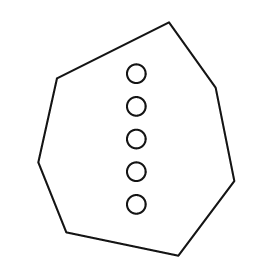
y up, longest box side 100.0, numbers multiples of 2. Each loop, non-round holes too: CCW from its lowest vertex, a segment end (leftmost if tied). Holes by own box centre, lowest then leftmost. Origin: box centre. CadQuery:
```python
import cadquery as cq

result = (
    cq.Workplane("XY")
    .moveTo(18.0, -50.0)
    .lineTo(42.0, -18.0)
    .lineTo(34.0, 22.0)
    .lineTo(14.0, 50.0)
    .lineTo(-34.0, 26.0)
    .lineTo(-42.0, -10.0)
    .lineTo(-30.0, -40.0)
    .close()
    .moveTo(0.0, -28.0)
    .circle(4.0)
    .moveTo(0.0, -14.0)
    .circle(4.0)
    .moveTo(0.0, 0.0)
    .circle(4.0)
    .moveTo(0.0, 14.0)
    .circle(4.0)
    .moveTo(0.0, 28.0)
    .circle(4.0)
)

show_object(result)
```